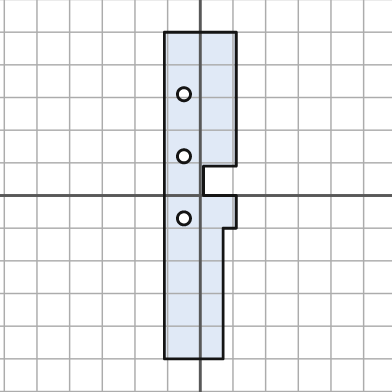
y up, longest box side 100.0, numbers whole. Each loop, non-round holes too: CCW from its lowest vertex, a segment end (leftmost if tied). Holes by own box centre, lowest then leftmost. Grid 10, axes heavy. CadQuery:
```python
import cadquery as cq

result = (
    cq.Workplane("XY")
    .moveTo(-11.0, -50.0)
    .lineTo(7.0, -50.0)
    .lineTo(7.0, -10.0)
    .lineTo(11.0, -10.0)
    .lineTo(11.0, 0.0)
    .lineTo(1.0, 0.0)
    .lineTo(1.0, 9.0)
    .lineTo(11.0, 9.0)
    .lineTo(11.0, 50.0)
    .lineTo(-11.0, 50.0)
    .close()
    .moveTo(-5.0, -7.0)
    .circle(2.0)
    .moveTo(-5.0, 12.0)
    .circle(2.0)
    .moveTo(-5.0, 31.0)
    .circle(2.0)
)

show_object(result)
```